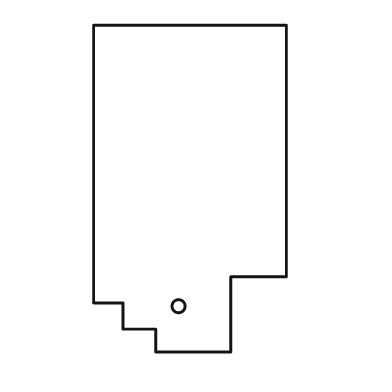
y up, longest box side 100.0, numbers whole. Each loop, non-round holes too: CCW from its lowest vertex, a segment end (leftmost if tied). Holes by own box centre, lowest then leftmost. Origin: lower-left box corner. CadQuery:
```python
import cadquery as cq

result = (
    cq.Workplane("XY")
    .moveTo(19.0, 0.0)
    .lineTo(42.0, 0.0)
    .lineTo(42.0, 23.0)
    .lineTo(59.0, 23.0)
    .lineTo(59.0, 100.0)
    .lineTo(0.0, 100.0)
    .lineTo(0.0, 15.0)
    .lineTo(9.0, 15.0)
    .lineTo(9.0, 7.0)
    .lineTo(19.0, 7.0)
    .close()
    .moveTo(26.0, 14.0)
    .circle(2.0)
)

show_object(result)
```